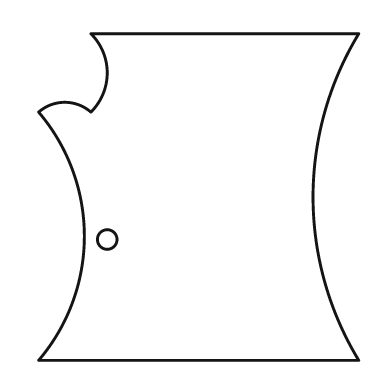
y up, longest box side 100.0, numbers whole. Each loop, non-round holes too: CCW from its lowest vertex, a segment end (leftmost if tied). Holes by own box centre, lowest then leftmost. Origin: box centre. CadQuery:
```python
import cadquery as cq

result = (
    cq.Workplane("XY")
    .moveTo(-49.0, -50.0)
    .lineTo(49.0, -50.0)
    .threePointArc((35.0, 0.0), (49.0, 50.0))
    .lineTo(-33.0, 50.0)
    .threePointArc((-28.0, 38.0), (-33.0, 26.0))
    .threePointArc((-41.0, 29.0), (-49.0, 26.0))
    .threePointArc((-35.0, -12.0), (-49.0, -50.0))
    .close()
    .moveTo(-28.0, -13.0)
    .circle(3.0)
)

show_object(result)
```